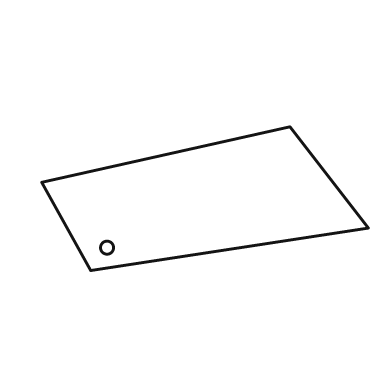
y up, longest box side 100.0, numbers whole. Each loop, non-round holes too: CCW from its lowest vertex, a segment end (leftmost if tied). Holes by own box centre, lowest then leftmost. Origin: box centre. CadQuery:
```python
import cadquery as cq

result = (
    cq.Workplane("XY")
    .moveTo(-35.0, -22.0)
    .lineTo(50.0, -9.0)
    .lineTo(26.0, 22.0)
    .lineTo(-50.0, 5.0)
    .close()
    .moveTo(-30.0, -15.0)
    .circle(2.0)
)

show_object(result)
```